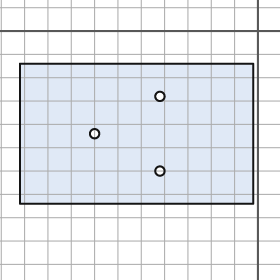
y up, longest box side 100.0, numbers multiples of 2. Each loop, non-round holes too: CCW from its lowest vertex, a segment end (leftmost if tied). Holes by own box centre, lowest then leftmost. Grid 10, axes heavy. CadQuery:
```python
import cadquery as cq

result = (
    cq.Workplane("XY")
    .moveTo(-102.0, -74.0)
    .lineTo(-2.0, -74.0)
    .lineTo(-2.0, -14.0)
    .lineTo(-102.0, -14.0)
    .close()
    .moveTo(-42.0, -60.0)
    .circle(2.0)
    .moveTo(-70.0, -44.0)
    .circle(2.0)
    .moveTo(-42.0, -28.0)
    .circle(2.0)
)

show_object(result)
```